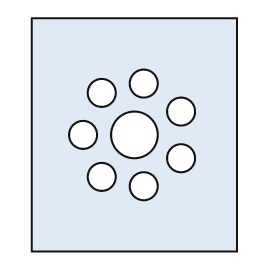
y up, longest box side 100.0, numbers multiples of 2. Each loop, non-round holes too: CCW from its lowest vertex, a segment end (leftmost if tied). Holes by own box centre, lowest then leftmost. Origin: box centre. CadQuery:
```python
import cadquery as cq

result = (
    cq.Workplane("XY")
    .moveTo(-44.0, -50.0)
    .lineTo(44.0, -50.0)
    .lineTo(44.0, 50.0)
    .lineTo(-44.0, 50.0)
    .close()
    .moveTo(4.0, -22.0)
    .circle(6.0)
    .moveTo(-14.0, -18.0)
    .circle(6.0)
    .moveTo(20.0, -10.0)
    .circle(6.0)
    .moveTo(-22.0, 0.0)
    .circle(6.0)
    .moveTo(0.0, 0.0)
    .circle(10.0)
    .moveTo(20.0, 10.0)
    .circle(6.0)
    .moveTo(-14.0, 18.0)
    .circle(6.0)
    .moveTo(4.0, 22.0)
    .circle(6.0)
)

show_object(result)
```